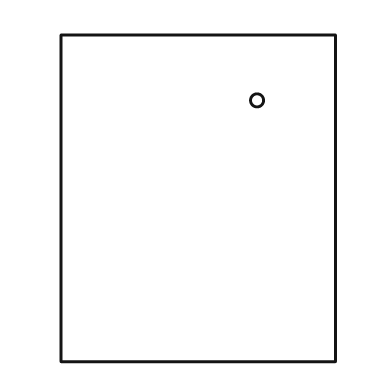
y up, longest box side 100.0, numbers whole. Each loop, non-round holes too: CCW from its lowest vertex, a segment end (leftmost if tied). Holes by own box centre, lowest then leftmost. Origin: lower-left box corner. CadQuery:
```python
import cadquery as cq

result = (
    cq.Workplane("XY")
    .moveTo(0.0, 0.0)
    .lineTo(84.0, 0.0)
    .lineTo(84.0, 100.0)
    .lineTo(0.0, 100.0)
    .close()
    .moveTo(60.0, 80.0)
    .circle(2.0)
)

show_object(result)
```